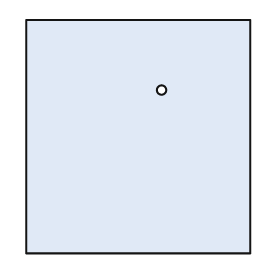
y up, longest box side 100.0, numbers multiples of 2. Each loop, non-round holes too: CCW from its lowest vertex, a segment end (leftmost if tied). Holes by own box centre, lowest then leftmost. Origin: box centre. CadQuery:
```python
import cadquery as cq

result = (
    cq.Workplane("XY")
    .moveTo(-48.0, -50.0)
    .lineTo(48.0, -50.0)
    .lineTo(48.0, 50.0)
    .lineTo(-48.0, 50.0)
    .close()
    .moveTo(10.0, 20.0)
    .circle(2.0)
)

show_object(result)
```